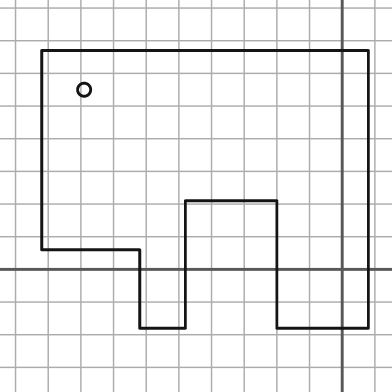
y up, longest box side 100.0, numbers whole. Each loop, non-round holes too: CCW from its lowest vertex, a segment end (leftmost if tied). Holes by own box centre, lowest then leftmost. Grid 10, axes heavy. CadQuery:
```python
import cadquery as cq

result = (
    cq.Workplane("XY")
    .moveTo(-62.0, -18.0)
    .lineTo(-48.0, -18.0)
    .lineTo(-48.0, 21.0)
    .lineTo(-20.0, 21.0)
    .lineTo(-20.0, -18.0)
    .lineTo(8.0, -18.0)
    .lineTo(8.0, 67.0)
    .lineTo(-92.0, 67.0)
    .lineTo(-92.0, 6.0)
    .lineTo(-62.0, 6.0)
    .close()
    .moveTo(-79.0, 55.0)
    .circle(2.0)
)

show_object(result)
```